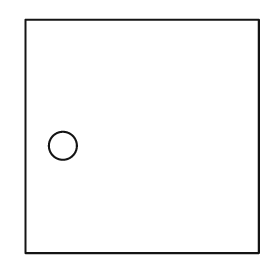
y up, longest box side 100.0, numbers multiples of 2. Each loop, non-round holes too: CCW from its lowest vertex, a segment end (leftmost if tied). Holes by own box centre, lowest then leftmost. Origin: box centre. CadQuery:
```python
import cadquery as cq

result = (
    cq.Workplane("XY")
    .moveTo(-50.0, -50.0)
    .lineTo(50.0, -50.0)
    .lineTo(50.0, 50.0)
    .lineTo(-50.0, 50.0)
    .close()
    .moveTo(-34.0, -4.0)
    .circle(6.0)
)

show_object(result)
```